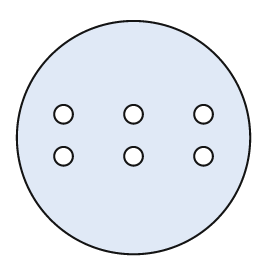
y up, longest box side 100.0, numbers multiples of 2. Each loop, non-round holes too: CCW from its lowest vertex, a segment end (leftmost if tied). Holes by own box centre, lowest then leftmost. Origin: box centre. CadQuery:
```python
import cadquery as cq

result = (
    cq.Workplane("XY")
    .moveTo(0.0, 0.0)
    .circle(50.0)
    .moveTo(-30.0, -8.0)
    .circle(4.0)
    .moveTo(0.0, -8.0)
    .circle(4.0)
    .moveTo(30.0, -8.0)
    .circle(4.0)
    .moveTo(-30.0, 10.0)
    .circle(4.0)
    .moveTo(0.0, 10.0)
    .circle(4.0)
    .moveTo(30.0, 10.0)
    .circle(4.0)
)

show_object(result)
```